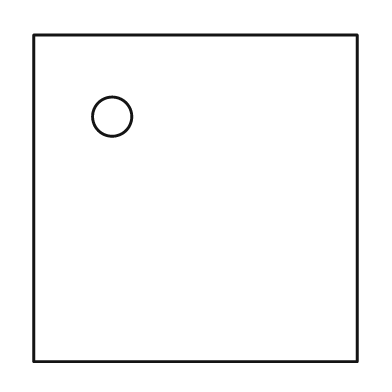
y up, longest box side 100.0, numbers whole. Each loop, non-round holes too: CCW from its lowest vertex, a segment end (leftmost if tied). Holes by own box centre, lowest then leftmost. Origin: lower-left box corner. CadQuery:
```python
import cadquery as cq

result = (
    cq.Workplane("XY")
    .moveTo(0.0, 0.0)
    .lineTo(99.0, 0.0)
    .lineTo(99.0, 100.0)
    .lineTo(0.0, 100.0)
    .close()
    .moveTo(24.0, 75.0)
    .circle(6.0)
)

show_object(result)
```